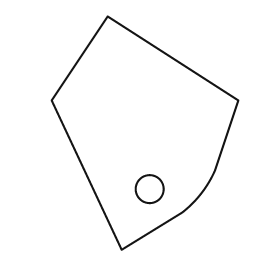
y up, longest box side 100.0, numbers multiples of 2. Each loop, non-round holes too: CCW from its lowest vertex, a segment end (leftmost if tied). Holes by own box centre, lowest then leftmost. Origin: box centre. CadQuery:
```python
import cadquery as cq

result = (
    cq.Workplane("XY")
    .moveTo(-10.0, -50.0)
    .lineTo(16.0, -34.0)
    .threePointArc((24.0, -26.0), (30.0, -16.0))
    .lineTo(40.0, 14.0)
    .lineTo(-16.0, 50.0)
    .lineTo(-40.0, 14.0)
    .close()
    .moveTo(2.0, -24.0)
    .circle(6.0)
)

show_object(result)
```